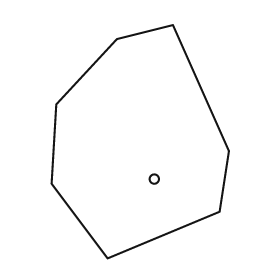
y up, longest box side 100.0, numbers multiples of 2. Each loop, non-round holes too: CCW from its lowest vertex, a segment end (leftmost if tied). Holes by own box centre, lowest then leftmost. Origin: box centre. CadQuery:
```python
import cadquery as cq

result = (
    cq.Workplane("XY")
    .moveTo(-14.0, -50.0)
    .lineTo(34.0, -30.0)
    .lineTo(38.0, -4.0)
    .lineTo(14.0, 50.0)
    .lineTo(-10.0, 44.0)
    .lineTo(-36.0, 16.0)
    .lineTo(-38.0, -18.0)
    .close()
    .moveTo(6.0, -16.0)
    .circle(2.0)
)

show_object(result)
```